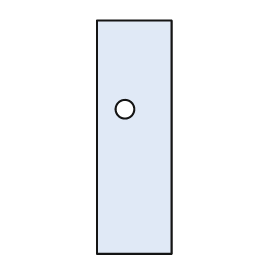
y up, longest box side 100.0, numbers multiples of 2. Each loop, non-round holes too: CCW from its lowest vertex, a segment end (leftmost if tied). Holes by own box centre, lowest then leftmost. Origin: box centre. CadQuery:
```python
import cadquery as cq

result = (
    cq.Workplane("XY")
    .moveTo(-16.0, -50.0)
    .lineTo(16.0, -50.0)
    .lineTo(16.0, 50.0)
    .lineTo(-16.0, 50.0)
    .close()
    .moveTo(-4.0, 12.0)
    .circle(4.0)
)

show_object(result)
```